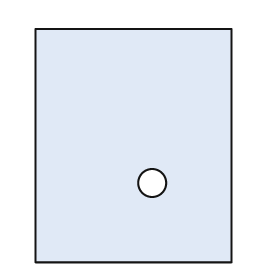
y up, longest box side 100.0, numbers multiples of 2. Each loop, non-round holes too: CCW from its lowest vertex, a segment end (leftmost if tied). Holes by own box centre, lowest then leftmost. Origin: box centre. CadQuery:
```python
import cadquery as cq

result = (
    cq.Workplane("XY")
    .moveTo(-42.0, -50.0)
    .lineTo(42.0, -50.0)
    .lineTo(42.0, 50.0)
    .lineTo(-42.0, 50.0)
    .close()
    .moveTo(8.0, -16.0)
    .circle(6.0)
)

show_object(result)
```